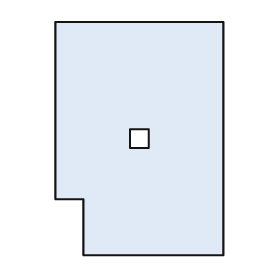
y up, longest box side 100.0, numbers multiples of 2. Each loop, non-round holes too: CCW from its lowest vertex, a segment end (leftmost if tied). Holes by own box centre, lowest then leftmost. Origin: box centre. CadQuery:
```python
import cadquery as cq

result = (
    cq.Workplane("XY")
    .moveTo(-24.0, -50.0)
    .lineTo(36.0, -50.0)
    .lineTo(36.0, 50.0)
    .lineTo(-36.0, 50.0)
    .lineTo(-36.0, -26.0)
    .lineTo(-24.0, -26.0)
    .close()
    .moveTo(-4.0, -4.0)
    .lineTo(4.0, -4.0)
    .lineTo(4.0, 4.0)
    .lineTo(-4.0, 4.0)
    .close()
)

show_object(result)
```